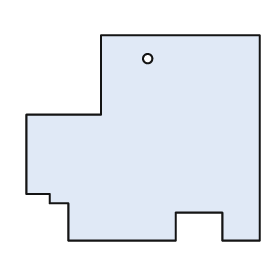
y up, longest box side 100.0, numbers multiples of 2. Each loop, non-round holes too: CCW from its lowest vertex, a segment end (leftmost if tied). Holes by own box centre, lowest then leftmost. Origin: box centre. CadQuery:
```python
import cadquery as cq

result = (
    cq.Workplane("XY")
    .moveTo(-32.0, -44.0)
    .lineTo(14.0, -44.0)
    .lineTo(14.0, -32.0)
    .lineTo(34.0, -32.0)
    .lineTo(34.0, -44.0)
    .lineTo(50.0, -44.0)
    .lineTo(50.0, 44.0)
    .lineTo(-18.0, 44.0)
    .lineTo(-18.0, 10.0)
    .lineTo(-50.0, 10.0)
    .lineTo(-50.0, -24.0)
    .lineTo(-40.0, -24.0)
    .lineTo(-40.0, -28.0)
    .lineTo(-32.0, -28.0)
    .close()
    .moveTo(2.0, 34.0)
    .circle(2.0)
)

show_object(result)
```